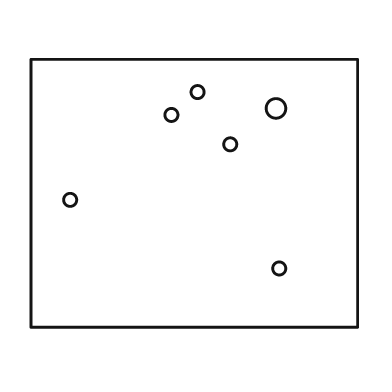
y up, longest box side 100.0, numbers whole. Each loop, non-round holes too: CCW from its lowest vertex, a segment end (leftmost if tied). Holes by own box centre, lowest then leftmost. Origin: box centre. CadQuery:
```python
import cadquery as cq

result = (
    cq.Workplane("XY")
    .moveTo(-50.0, -41.0)
    .lineTo(50.0, -41.0)
    .lineTo(50.0, 41.0)
    .lineTo(-50.0, 41.0)
    .close()
    .moveTo(26.0, -23.0)
    .circle(2.0)
    .moveTo(-38.0, -2.0)
    .circle(2.0)
    .moveTo(11.0, 15.0)
    .circle(2.0)
    .moveTo(-7.0, 24.0)
    .circle(2.0)
    .moveTo(25.0, 26.0)
    .circle(3.0)
    .moveTo(1.0, 31.0)
    .circle(2.0)
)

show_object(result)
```